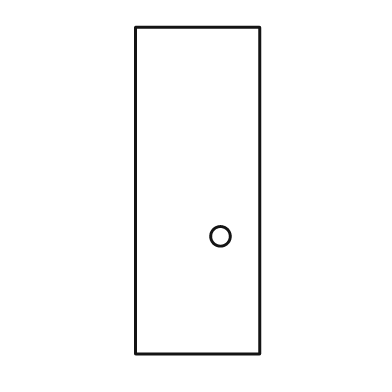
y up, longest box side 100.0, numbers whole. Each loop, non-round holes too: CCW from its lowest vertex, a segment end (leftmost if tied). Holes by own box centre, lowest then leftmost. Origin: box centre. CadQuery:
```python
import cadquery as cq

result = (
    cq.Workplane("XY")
    .moveTo(-19.0, -50.0)
    .lineTo(19.0, -50.0)
    .lineTo(19.0, 50.0)
    .lineTo(-19.0, 50.0)
    .close()
    .moveTo(7.0, -14.0)
    .circle(3.0)
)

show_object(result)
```